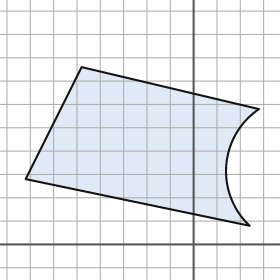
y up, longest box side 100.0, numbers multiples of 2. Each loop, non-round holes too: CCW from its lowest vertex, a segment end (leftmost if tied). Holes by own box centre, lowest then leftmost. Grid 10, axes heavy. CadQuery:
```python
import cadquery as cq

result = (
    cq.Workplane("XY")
    .moveTo(24.0, 8.0)
    .threePointArc((14.0, 34.0), (28.0, 58.0))
    .lineTo(-48.0, 76.0)
    .lineTo(-72.0, 28.0)
    .close()
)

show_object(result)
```